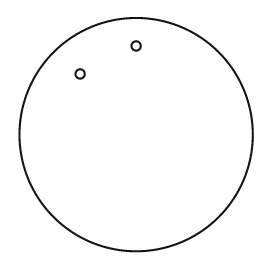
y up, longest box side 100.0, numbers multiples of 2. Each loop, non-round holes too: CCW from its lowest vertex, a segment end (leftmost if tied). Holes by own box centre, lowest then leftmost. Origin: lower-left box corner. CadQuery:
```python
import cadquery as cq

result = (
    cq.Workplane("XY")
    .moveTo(50.0, 50.0)
    .circle(50.0)
    .moveTo(26.0, 76.0)
    .circle(2.0)
    .moveTo(50.0, 88.0)
    .circle(2.0)
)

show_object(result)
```